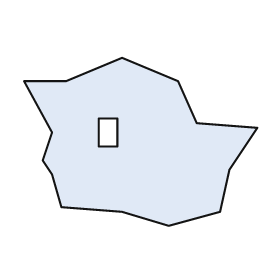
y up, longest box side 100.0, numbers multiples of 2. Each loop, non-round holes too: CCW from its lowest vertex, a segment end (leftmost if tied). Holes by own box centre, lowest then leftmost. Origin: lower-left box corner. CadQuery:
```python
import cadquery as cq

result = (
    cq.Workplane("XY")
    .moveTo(62.0, 0.0)
    .lineTo(84.0, 6.0)
    .lineTo(88.0, 24.0)
    .lineTo(100.0, 42.0)
    .lineTo(74.0, 44.0)
    .lineTo(66.0, 62.0)
    .lineTo(42.0, 72.0)
    .lineTo(18.0, 62.0)
    .lineTo(0.0, 62.0)
    .lineTo(12.0, 40.0)
    .lineTo(8.0, 28.0)
    .lineTo(12.0, 22.0)
    .lineTo(16.0, 8.0)
    .lineTo(42.0, 6.0)
    .close()
    .moveTo(32.0, 34.0)
    .lineTo(40.0, 34.0)
    .lineTo(40.0, 46.0)
    .lineTo(32.0, 46.0)
    .close()
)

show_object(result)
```